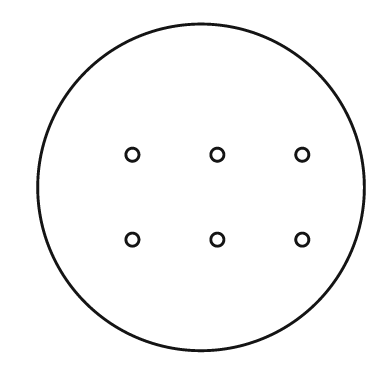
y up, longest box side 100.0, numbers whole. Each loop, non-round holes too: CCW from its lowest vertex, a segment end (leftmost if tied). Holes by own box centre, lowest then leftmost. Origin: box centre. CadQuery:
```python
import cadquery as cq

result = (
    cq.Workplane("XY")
    .moveTo(0.0, 0.0)
    .circle(50.0)
    .moveTo(-21.0, -16.0)
    .circle(2.0)
    .moveTo(5.0, -16.0)
    .circle(2.0)
    .moveTo(31.0, -16.0)
    .circle(2.0)
    .moveTo(-21.0, 10.0)
    .circle(2.0)
    .moveTo(5.0, 10.0)
    .circle(2.0)
    .moveTo(31.0, 10.0)
    .circle(2.0)
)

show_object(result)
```